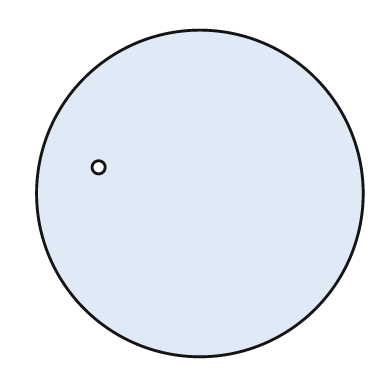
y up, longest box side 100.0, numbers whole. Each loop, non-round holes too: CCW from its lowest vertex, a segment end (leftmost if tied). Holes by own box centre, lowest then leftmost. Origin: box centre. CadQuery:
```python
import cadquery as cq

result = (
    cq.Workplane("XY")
    .moveTo(0.0, 0.0)
    .circle(50.0)
    .moveTo(-31.0, 8.0)
    .circle(2.0)
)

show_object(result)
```